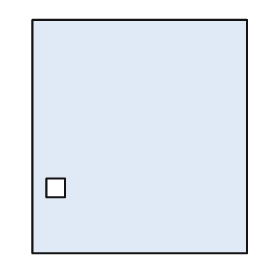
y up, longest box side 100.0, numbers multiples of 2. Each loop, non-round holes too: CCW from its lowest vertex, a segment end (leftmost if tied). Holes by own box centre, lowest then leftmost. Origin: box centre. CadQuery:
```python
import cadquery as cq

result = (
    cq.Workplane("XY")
    .moveTo(-46.0, -50.0)
    .lineTo(46.0, -50.0)
    .lineTo(46.0, 50.0)
    .lineTo(-46.0, 50.0)
    .close()
    .moveTo(-40.0, -26.0)
    .lineTo(-32.0, -26.0)
    .lineTo(-32.0, -18.0)
    .lineTo(-40.0, -18.0)
    .close()
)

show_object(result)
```